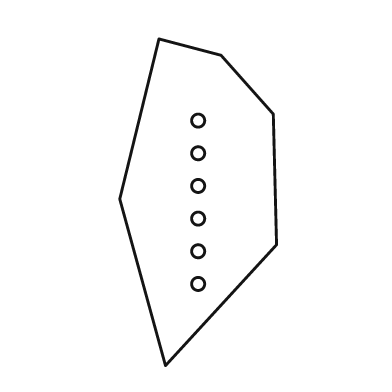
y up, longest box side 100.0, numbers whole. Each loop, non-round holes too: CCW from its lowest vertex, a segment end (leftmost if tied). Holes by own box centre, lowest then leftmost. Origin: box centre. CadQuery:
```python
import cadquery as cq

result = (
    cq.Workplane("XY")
    .moveTo(-10.0, -50.0)
    .lineTo(24.0, -13.0)
    .lineTo(23.0, 27.0)
    .lineTo(7.0, 45.0)
    .lineTo(-12.0, 50.0)
    .lineTo(-24.0, 1.0)
    .close()
    .moveTo(0.0, -25.0)
    .circle(2.0)
    .moveTo(0.0, -15.0)
    .circle(2.0)
    .moveTo(0.0, -5.0)
    .circle(2.0)
    .moveTo(0.0, 5.0)
    .circle(2.0)
    .moveTo(0.0, 15.0)
    .circle(2.0)
    .moveTo(0.0, 25.0)
    .circle(2.0)
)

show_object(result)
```